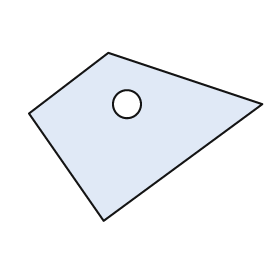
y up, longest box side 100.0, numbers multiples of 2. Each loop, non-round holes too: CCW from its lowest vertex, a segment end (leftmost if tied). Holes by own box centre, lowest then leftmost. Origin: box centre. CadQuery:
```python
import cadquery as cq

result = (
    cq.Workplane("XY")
    .moveTo(-18.0, -36.0)
    .lineTo(50.0, 14.0)
    .lineTo(-16.0, 36.0)
    .lineTo(-50.0, 10.0)
    .close()
    .moveTo(-8.0, 14.0)
    .circle(6.0)
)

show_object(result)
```